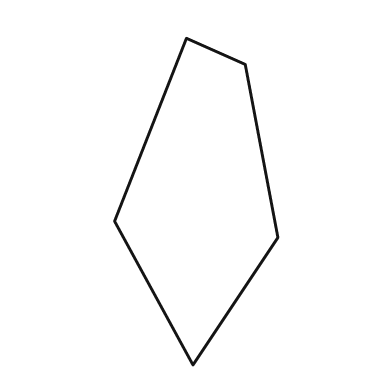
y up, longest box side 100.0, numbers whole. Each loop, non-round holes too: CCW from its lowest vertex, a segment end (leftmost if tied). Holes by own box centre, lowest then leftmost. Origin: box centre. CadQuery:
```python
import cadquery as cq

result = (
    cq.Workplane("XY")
    .moveTo(-1.0, -50.0)
    .lineTo(25.0, -11.0)
    .lineTo(15.0, 42.0)
    .lineTo(-3.0, 50.0)
    .lineTo(-25.0, -6.0)
    .close()
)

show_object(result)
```